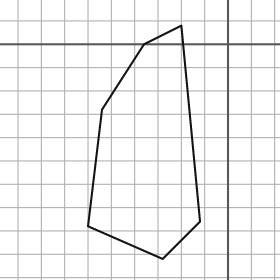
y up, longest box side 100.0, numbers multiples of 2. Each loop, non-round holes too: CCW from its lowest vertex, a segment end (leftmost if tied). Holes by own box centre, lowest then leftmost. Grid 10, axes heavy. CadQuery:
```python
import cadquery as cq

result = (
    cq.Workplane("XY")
    .moveTo(-28.0, -92.0)
    .lineTo(-12.0, -76.0)
    .lineTo(-20.0, 8.0)
    .lineTo(-36.0, 0.0)
    .lineTo(-54.0, -28.0)
    .lineTo(-60.0, -78.0)
    .close()
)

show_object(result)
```